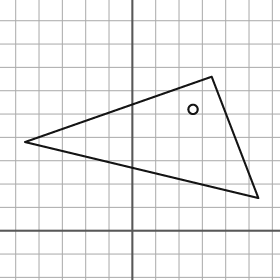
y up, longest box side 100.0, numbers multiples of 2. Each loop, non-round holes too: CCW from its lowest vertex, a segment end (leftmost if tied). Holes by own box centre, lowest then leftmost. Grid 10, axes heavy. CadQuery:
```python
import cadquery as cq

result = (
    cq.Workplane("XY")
    .moveTo(54.0, 14.0)
    .lineTo(34.0, 66.0)
    .lineTo(-46.0, 38.0)
    .close()
    .moveTo(26.0, 52.0)
    .circle(2.0)
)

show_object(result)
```